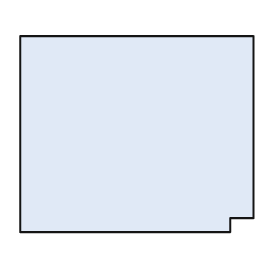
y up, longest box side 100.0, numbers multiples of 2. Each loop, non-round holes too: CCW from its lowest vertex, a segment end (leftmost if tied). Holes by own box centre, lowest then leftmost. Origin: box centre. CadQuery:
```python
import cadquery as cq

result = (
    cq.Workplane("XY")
    .moveTo(-50.0, -42.0)
    .lineTo(40.0, -42.0)
    .lineTo(40.0, -36.0)
    .lineTo(50.0, -36.0)
    .lineTo(50.0, 42.0)
    .lineTo(-50.0, 42.0)
    .close()
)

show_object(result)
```